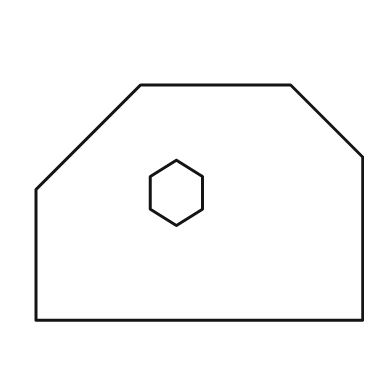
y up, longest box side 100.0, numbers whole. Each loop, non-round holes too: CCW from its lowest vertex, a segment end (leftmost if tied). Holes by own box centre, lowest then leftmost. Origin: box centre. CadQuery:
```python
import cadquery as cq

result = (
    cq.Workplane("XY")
    .moveTo(-50.0, -36.0)
    .lineTo(50.0, -36.0)
    .lineTo(50.0, 14.0)
    .lineTo(28.0, 36.0)
    .lineTo(-18.0, 36.0)
    .lineTo(-50.0, 4.0)
    .close()
    .moveTo(-7.0, -7.0)
    .lineTo(1.0, -2.0)
    .lineTo(1.0, 8.0)
    .lineTo(-7.0, 13.0)
    .lineTo(-15.0, 8.0)
    .lineTo(-15.0, -2.0)
    .close()
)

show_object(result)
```